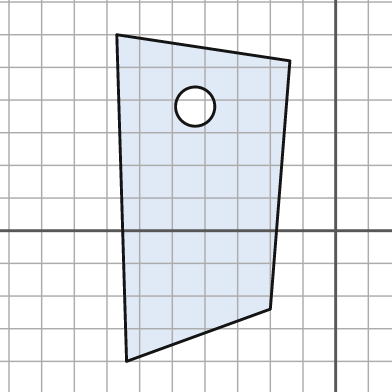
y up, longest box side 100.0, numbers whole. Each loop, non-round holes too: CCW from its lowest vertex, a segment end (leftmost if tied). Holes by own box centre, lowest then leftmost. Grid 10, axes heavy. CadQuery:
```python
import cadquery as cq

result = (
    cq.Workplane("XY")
    .moveTo(-64.0, -40.0)
    .lineTo(-20.0, -24.0)
    .lineTo(-14.0, 52.0)
    .lineTo(-67.0, 60.0)
    .close()
    .moveTo(-43.0, 38.0)
    .circle(6.0)
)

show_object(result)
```